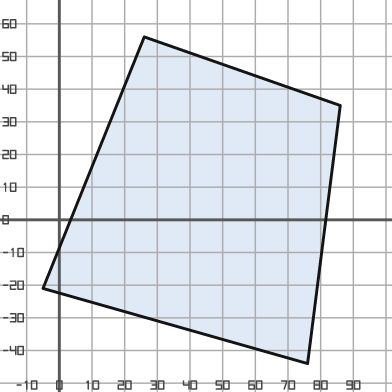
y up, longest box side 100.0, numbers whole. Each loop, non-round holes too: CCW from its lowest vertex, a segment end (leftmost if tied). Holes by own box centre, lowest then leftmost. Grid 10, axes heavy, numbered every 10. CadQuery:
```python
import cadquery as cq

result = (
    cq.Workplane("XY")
    .moveTo(76.0, -44.0)
    .lineTo(86.0, 35.0)
    .lineTo(26.0, 56.0)
    .lineTo(-5.0, -21.0)
    .close()
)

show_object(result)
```